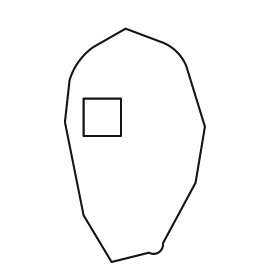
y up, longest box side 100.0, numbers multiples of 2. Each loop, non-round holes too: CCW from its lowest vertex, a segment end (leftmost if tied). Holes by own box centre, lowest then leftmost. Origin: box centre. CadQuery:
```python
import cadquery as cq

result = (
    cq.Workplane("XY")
    .moveTo(-10.0, -50.0)
    .lineTo(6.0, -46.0)
    .threePointArc((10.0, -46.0), (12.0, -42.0))
    .lineTo(26.0, -16.0)
    .lineTo(30.0, 8.0)
    .lineTo(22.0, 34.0)
    .threePointArc((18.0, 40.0), (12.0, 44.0))
    .lineTo(-4.0, 50.0)
    .lineTo(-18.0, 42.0)
    .threePointArc((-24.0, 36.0), (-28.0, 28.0))
    .lineTo(-30.0, 10.0)
    .lineTo(-22.0, -30.0)
    .close()
    .moveTo(-22.0, 4.0)
    .lineTo(-6.0, 4.0)
    .lineTo(-6.0, 20.0)
    .lineTo(-22.0, 20.0)
    .close()
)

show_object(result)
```